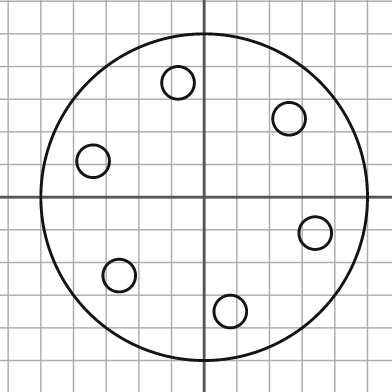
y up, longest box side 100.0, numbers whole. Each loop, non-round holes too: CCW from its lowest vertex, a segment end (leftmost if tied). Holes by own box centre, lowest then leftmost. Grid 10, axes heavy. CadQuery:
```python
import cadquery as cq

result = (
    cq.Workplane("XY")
    .moveTo(0.0, 0.0)
    .circle(50.0)
    .moveTo(8.0, -35.0)
    .circle(5.0)
    .moveTo(-26.0, -24.0)
    .circle(5.0)
    .moveTo(34.0, -11.0)
    .circle(5.0)
    .moveTo(-34.0, 11.0)
    .circle(5.0)
    .moveTo(26.0, 24.0)
    .circle(5.0)
    .moveTo(-8.0, 35.0)
    .circle(5.0)
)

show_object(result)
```